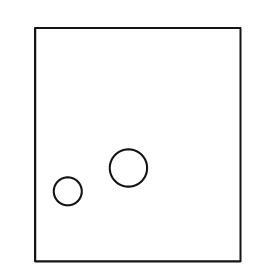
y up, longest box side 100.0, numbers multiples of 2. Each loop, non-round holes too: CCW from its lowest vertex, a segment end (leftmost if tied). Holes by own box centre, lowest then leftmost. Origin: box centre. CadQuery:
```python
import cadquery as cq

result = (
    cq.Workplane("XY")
    .moveTo(-44.0, -50.0)
    .lineTo(44.0, -50.0)
    .lineTo(44.0, 50.0)
    .lineTo(-44.0, 50.0)
    .close()
    .moveTo(-30.0, -20.0)
    .circle(6.0)
    .moveTo(-4.0, -10.0)
    .circle(8.0)
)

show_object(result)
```